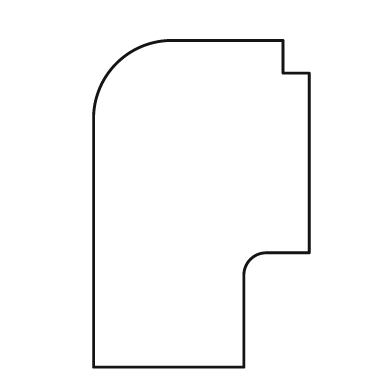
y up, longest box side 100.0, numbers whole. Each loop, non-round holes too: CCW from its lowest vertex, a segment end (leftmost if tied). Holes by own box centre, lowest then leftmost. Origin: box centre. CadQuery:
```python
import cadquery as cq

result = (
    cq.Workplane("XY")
    .moveTo(-33.0, -50.0)
    .lineTo(13.0, -50.0)
    .lineTo(13.0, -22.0)
    .threePointArc((15.0, -17.0), (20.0, -15.0))
    .lineTo(33.0, -15.0)
    .lineTo(33.0, 40.0)
    .lineTo(25.0, 40.0)
    .lineTo(25.0, 50.0)
    .lineTo(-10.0, 50.0)
    .threePointArc((-26.0, 43.0), (-33.0, 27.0))
    .close()
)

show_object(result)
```